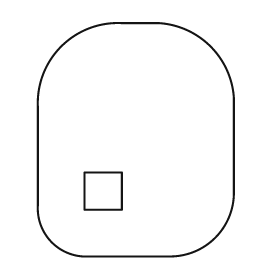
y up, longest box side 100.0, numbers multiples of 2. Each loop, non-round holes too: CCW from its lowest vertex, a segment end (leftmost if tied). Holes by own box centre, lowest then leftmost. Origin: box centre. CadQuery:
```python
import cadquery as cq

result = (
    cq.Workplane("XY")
    .moveTo(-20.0, -50.0)
    .lineTo(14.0, -50.0)
    .threePointArc((34.0, -42.0), (42.0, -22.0))
    .lineTo(42.0, 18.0)
    .threePointArc((32.0, 40.0), (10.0, 50.0))
    .lineTo(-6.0, 50.0)
    .threePointArc((-32.0, 40.0), (-42.0, 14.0))
    .lineTo(-42.0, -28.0)
    .threePointArc((-36.0, -44.0), (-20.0, -50.0))
    .close()
    .moveTo(-22.0, -30.0)
    .lineTo(-6.0, -30.0)
    .lineTo(-6.0, -14.0)
    .lineTo(-22.0, -14.0)
    .close()
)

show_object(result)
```